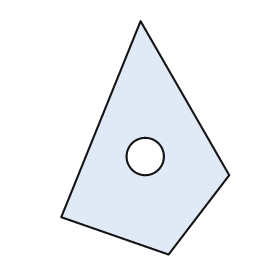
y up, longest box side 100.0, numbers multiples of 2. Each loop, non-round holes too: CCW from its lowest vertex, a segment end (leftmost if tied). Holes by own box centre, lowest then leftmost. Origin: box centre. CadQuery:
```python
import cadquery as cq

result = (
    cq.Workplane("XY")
    .moveTo(10.0, -50.0)
    .lineTo(36.0, -16.0)
    .lineTo(-2.0, 50.0)
    .lineTo(-36.0, -34.0)
    .close()
    .moveTo(0.0, -8.0)
    .circle(8.0)
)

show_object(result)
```